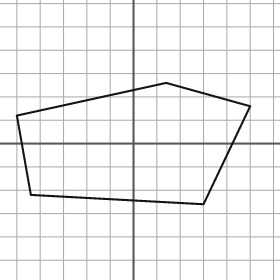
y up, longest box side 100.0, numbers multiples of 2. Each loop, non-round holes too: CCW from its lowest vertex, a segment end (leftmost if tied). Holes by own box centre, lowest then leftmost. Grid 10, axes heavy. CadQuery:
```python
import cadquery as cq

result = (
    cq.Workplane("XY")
    .moveTo(30.0, -26.0)
    .lineTo(50.0, 16.0)
    .lineTo(14.0, 26.0)
    .lineTo(-50.0, 12.0)
    .lineTo(-44.0, -22.0)
    .close()
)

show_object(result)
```